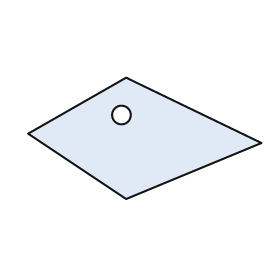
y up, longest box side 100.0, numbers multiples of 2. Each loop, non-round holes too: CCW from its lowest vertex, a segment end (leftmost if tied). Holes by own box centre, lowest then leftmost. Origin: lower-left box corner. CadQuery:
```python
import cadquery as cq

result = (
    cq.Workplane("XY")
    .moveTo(42.0, 0.0)
    .lineTo(100.0, 24.0)
    .lineTo(42.0, 52.0)
    .lineTo(0.0, 28.0)
    .close()
    .moveTo(40.0, 36.0)
    .circle(4.0)
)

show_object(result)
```